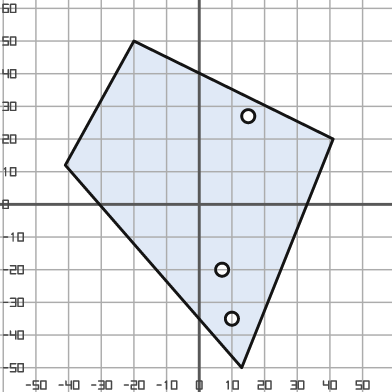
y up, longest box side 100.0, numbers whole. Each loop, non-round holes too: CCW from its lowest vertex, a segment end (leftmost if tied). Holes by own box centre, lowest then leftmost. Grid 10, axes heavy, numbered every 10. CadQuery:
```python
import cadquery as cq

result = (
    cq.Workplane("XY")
    .moveTo(13.0, -50.0)
    .lineTo(41.0, 20.0)
    .lineTo(-20.0, 50.0)
    .lineTo(-41.0, 12.0)
    .close()
    .moveTo(10.0, -35.0)
    .circle(2.0)
    .moveTo(7.0, -20.0)
    .circle(2.0)
    .moveTo(15.0, 27.0)
    .circle(2.0)
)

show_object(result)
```